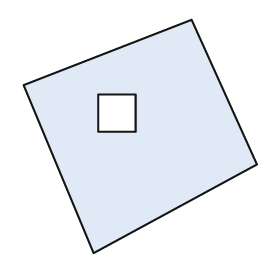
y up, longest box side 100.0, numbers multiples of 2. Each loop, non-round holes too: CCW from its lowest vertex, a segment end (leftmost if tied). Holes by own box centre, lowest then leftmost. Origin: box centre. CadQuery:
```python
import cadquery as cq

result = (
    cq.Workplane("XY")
    .moveTo(-20.0, -50.0)
    .lineTo(50.0, -12.0)
    .lineTo(22.0, 50.0)
    .lineTo(-50.0, 22.0)
    .close()
    .moveTo(-18.0, 2.0)
    .lineTo(-2.0, 2.0)
    .lineTo(-2.0, 18.0)
    .lineTo(-18.0, 18.0)
    .close()
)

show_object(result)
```